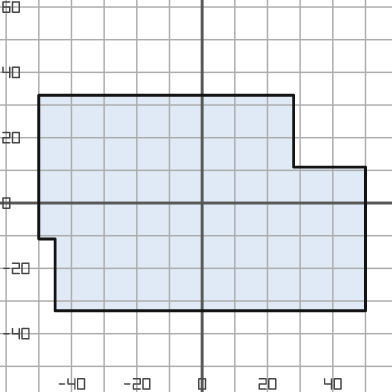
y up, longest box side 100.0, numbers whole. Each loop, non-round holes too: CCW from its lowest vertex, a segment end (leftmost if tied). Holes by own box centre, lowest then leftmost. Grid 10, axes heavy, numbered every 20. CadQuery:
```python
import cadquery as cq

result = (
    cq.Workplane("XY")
    .moveTo(-45.0, -33.0)
    .lineTo(50.0, -33.0)
    .lineTo(50.0, 11.0)
    .lineTo(28.0, 11.0)
    .lineTo(28.0, 33.0)
    .lineTo(-50.0, 33.0)
    .lineTo(-50.0, -11.0)
    .lineTo(-45.0, -11.0)
    .close()
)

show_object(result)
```